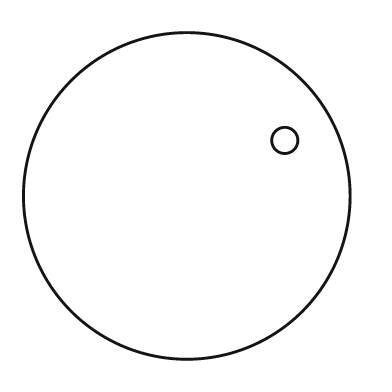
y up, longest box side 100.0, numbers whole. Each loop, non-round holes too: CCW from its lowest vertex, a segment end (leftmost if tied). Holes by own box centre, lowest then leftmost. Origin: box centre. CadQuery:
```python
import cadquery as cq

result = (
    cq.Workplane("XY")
    .moveTo(0.0, 0.0)
    .circle(50.0)
    .moveTo(30.0, 17.0)
    .circle(4.0)
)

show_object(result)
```